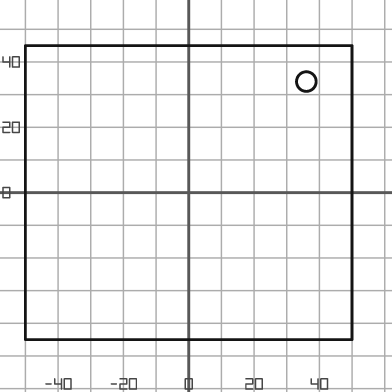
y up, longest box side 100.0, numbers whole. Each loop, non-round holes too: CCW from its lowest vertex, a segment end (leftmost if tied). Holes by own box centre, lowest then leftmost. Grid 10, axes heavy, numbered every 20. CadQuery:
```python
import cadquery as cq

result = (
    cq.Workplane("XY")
    .moveTo(-50.0, -45.0)
    .lineTo(50.0, -45.0)
    .lineTo(50.0, 45.0)
    .lineTo(-50.0, 45.0)
    .close()
    .moveTo(36.0, 34.0)
    .circle(3.0)
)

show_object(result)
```